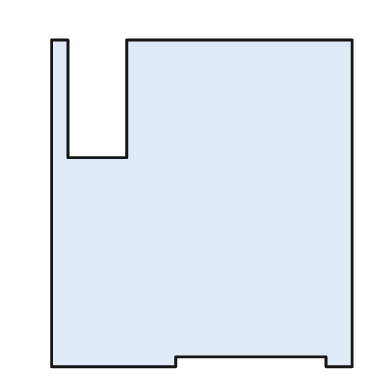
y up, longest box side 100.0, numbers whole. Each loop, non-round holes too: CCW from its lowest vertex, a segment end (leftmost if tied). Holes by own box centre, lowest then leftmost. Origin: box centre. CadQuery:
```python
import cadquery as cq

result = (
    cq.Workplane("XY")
    .moveTo(-46.0, -50.0)
    .lineTo(-8.0, -50.0)
    .lineTo(-8.0, -47.0)
    .lineTo(38.0, -47.0)
    .lineTo(38.0, -50.0)
    .lineTo(46.0, -50.0)
    .lineTo(46.0, 50.0)
    .lineTo(-23.0, 50.0)
    .lineTo(-23.0, 14.0)
    .lineTo(-41.0, 14.0)
    .lineTo(-41.0, 50.0)
    .lineTo(-46.0, 50.0)
    .close()
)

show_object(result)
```